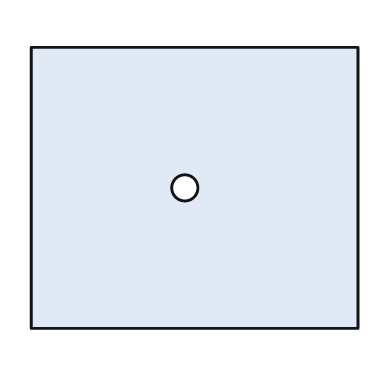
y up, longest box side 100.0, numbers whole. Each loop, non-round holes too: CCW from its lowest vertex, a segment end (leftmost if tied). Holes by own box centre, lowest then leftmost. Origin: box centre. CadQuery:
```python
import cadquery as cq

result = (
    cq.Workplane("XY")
    .moveTo(-50.0, -43.0)
    .lineTo(50.0, -43.0)
    .lineTo(50.0, 43.0)
    .lineTo(-50.0, 43.0)
    .close()
    .moveTo(-3.0, 0.0)
    .circle(4.0)
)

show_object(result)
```